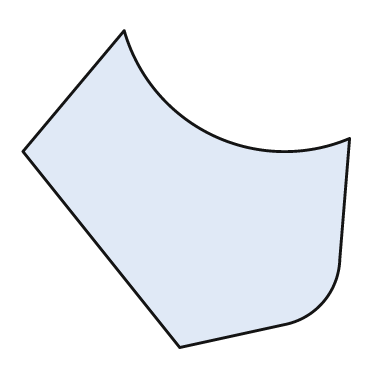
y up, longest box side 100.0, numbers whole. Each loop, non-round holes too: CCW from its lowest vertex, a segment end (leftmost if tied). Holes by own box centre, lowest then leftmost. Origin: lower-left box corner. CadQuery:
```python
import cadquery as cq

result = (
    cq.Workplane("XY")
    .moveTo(48.0, 0.0)
    .lineTo(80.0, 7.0)
    .threePointArc((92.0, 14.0), (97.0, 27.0))
    .lineTo(100.0, 64.0)
    .threePointArc((58.0, 65.0), (31.0, 97.0))
    .lineTo(0.0, 60.0)
    .close()
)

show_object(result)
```